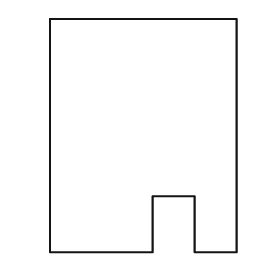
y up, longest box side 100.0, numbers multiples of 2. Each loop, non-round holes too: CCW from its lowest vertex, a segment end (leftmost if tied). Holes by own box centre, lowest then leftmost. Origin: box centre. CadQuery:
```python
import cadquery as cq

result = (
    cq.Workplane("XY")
    .moveTo(-40.0, -50.0)
    .lineTo(4.0, -50.0)
    .lineTo(4.0, -26.0)
    .lineTo(22.0, -26.0)
    .lineTo(22.0, -50.0)
    .lineTo(40.0, -50.0)
    .lineTo(40.0, 50.0)
    .lineTo(-40.0, 50.0)
    .close()
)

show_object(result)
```